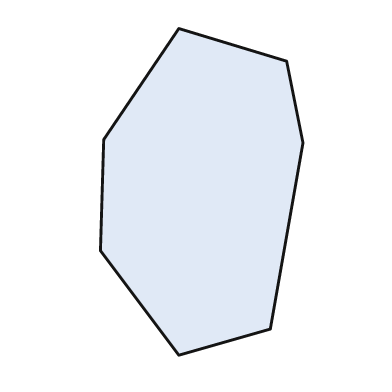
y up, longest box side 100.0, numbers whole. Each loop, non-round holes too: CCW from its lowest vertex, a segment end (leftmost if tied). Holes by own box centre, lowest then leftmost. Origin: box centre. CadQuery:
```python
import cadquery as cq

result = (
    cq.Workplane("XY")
    .moveTo(-7.0, -50.0)
    .lineTo(21.0, -42.0)
    .lineTo(31.0, 15.0)
    .lineTo(26.0, 40.0)
    .lineTo(-7.0, 50.0)
    .lineTo(-30.0, 16.0)
    .lineTo(-31.0, -18.0)
    .close()
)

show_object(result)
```